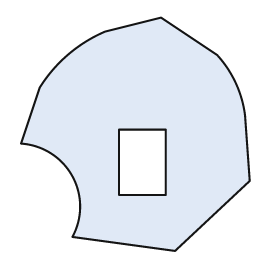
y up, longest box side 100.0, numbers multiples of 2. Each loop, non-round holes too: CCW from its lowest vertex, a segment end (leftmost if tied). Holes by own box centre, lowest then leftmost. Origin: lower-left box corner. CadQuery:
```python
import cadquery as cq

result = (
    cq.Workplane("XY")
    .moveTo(66.0, 0.0)
    .lineTo(98.0, 30.0)
    .lineTo(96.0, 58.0)
    .threePointArc((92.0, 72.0), (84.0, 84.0))
    .lineTo(60.0, 100.0)
    .lineTo(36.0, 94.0)
    .threePointArc((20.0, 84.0), (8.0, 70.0))
    .lineTo(0.0, 46.0)
    .threePointArc((22.0, 32.0), (22.0, 6.0))
    .close()
    .moveTo(42.0, 24.0)
    .lineTo(62.0, 24.0)
    .lineTo(62.0, 52.0)
    .lineTo(42.0, 52.0)
    .close()
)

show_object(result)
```